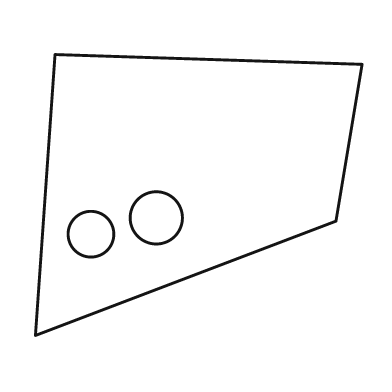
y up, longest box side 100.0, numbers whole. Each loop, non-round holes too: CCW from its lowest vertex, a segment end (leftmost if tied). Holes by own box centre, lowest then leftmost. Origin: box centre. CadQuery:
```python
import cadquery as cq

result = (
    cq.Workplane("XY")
    .moveTo(-50.0, -43.0)
    .lineTo(42.0, -8.0)
    .lineTo(50.0, 40.0)
    .lineTo(-44.0, 43.0)
    .close()
    .moveTo(-33.0, -12.0)
    .circle(7.0)
    .moveTo(-13.0, -7.0)
    .circle(8.0)
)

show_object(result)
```